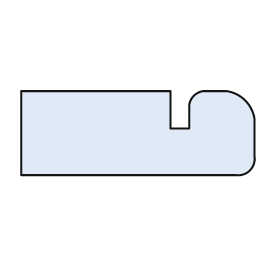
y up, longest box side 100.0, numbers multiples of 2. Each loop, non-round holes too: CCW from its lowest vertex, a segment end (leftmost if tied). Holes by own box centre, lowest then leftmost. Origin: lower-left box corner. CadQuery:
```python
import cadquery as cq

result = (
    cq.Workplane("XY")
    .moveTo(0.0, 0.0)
    .lineTo(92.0, 0.0)
    .threePointArc((98.0, 2.0), (100.0, 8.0))
    .lineTo(100.0, 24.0)
    .threePointArc((96.0, 32.0), (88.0, 36.0))
    .lineTo(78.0, 36.0)
    .threePointArc((74.0, 34.0), (72.0, 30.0))
    .lineTo(72.0, 20.0)
    .lineTo(64.0, 20.0)
    .lineTo(64.0, 36.0)
    .lineTo(0.0, 36.0)
    .close()
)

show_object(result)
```